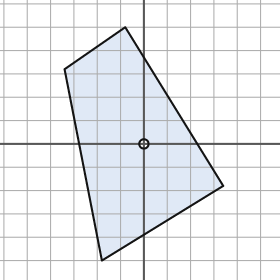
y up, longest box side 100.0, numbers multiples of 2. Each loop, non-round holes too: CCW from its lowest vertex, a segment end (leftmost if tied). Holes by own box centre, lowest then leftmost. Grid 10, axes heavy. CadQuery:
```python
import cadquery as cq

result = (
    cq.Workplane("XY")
    .moveTo(-18.0, -50.0)
    .lineTo(34.0, -18.0)
    .lineTo(-8.0, 50.0)
    .lineTo(-34.0, 32.0)
    .close()
    .moveTo(0.0, 0.0)
    .circle(2.0)
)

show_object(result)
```